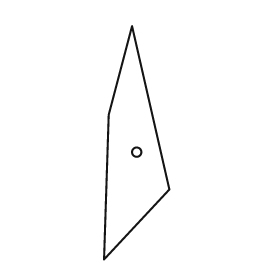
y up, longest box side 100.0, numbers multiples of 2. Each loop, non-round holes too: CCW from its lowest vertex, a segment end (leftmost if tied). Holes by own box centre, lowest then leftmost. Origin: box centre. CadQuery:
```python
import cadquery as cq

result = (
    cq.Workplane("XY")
    .moveTo(-14.0, -50.0)
    .lineTo(14.0, -20.0)
    .lineTo(-2.0, 50.0)
    .lineTo(-12.0, 12.0)
    .close()
    .moveTo(0.0, -4.0)
    .circle(2.0)
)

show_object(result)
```